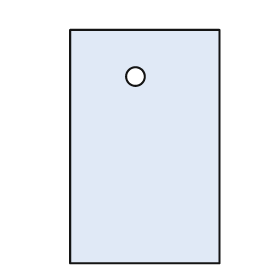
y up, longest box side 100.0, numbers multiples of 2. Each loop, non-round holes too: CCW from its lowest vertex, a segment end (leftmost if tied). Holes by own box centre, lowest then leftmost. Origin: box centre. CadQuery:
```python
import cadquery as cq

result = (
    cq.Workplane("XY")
    .moveTo(-32.0, -50.0)
    .lineTo(32.0, -50.0)
    .lineTo(32.0, 50.0)
    .lineTo(-32.0, 50.0)
    .close()
    .moveTo(-4.0, 30.0)
    .circle(4.0)
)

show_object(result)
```